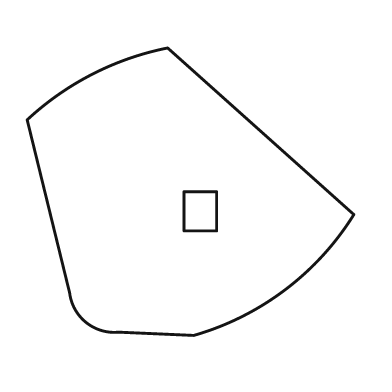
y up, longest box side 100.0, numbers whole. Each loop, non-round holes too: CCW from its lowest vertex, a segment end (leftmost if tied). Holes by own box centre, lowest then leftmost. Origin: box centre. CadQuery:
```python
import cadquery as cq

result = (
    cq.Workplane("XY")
    .moveTo(1.0, -44.0)
    .threePointArc((29.0, -30.0), (50.0, -7.0))
    .lineTo(-7.0, 44.0)
    .threePointArc((-30.0, 36.0), (-50.0, 22.0))
    .lineTo(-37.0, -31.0)
    .threePointArc((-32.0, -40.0), (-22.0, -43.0))
    .close()
    .moveTo(-2.0, -12.0)
    .lineTo(8.0, -12.0)
    .lineTo(8.0, 0.0)
    .lineTo(-2.0, 0.0)
    .close()
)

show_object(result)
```